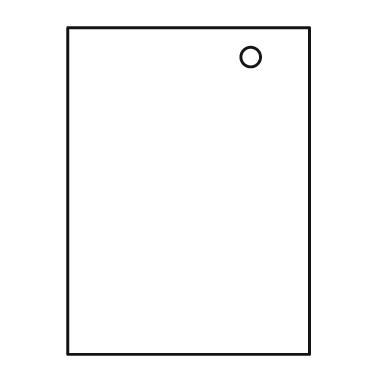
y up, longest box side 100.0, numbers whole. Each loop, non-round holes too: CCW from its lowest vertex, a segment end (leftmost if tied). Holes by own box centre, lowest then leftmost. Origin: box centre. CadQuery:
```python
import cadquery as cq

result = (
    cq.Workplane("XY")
    .moveTo(-37.0, -50.0)
    .lineTo(37.0, -50.0)
    .lineTo(37.0, 50.0)
    .lineTo(-37.0, 50.0)
    .close()
    .moveTo(19.0, 41.0)
    .circle(3.0)
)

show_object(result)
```